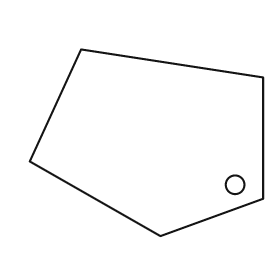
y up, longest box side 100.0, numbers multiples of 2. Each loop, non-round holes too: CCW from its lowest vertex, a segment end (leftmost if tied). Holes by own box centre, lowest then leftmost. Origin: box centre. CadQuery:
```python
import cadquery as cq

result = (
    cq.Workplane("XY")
    .moveTo(6.0, -40.0)
    .lineTo(50.0, -24.0)
    .lineTo(50.0, 28.0)
    .lineTo(-28.0, 40.0)
    .lineTo(-50.0, -8.0)
    .close()
    .moveTo(38.0, -18.0)
    .circle(4.0)
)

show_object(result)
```